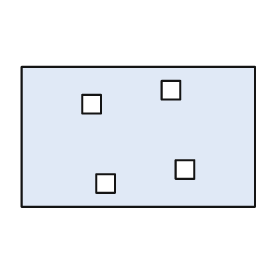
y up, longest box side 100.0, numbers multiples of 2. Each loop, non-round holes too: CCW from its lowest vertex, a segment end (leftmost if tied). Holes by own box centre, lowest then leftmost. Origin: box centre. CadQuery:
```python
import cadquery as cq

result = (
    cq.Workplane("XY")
    .moveTo(-50.0, -30.0)
    .lineTo(50.0, -30.0)
    .lineTo(50.0, 30.0)
    .lineTo(-50.0, 30.0)
    .close()
    .moveTo(-18.0, -24.0)
    .lineTo(-10.0, -24.0)
    .lineTo(-10.0, -16.0)
    .lineTo(-18.0, -16.0)
    .close()
    .moveTo(16.0, -18.0)
    .lineTo(24.0, -18.0)
    .lineTo(24.0, -10.0)
    .lineTo(16.0, -10.0)
    .close()
    .moveTo(-24.0, 10.0)
    .lineTo(-16.0, 10.0)
    .lineTo(-16.0, 18.0)
    .lineTo(-24.0, 18.0)
    .close()
    .moveTo(10.0, 16.0)
    .lineTo(18.0, 16.0)
    .lineTo(18.0, 24.0)
    .lineTo(10.0, 24.0)
    .close()
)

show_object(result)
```